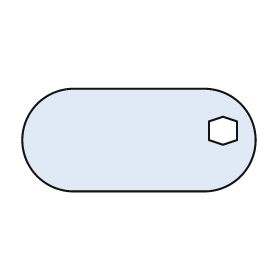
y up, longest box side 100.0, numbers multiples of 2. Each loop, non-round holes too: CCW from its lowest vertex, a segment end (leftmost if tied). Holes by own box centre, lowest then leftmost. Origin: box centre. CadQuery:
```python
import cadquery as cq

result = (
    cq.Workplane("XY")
    .moveTo(-28.0, -22.0)
    .lineTo(28.0, -22.0)
    .threePointArc((50.0, 0.0), (28.0, 22.0))
    .lineTo(-28.0, 22.0)
    .threePointArc((-50.0, 0.0), (-28.0, -22.0))
    .close()
    .moveTo(36.0, -2.0)
    .lineTo(42.0, 0.0)
    .lineTo(42.0, 8.0)
    .lineTo(36.0, 10.0)
    .lineTo(30.0, 8.0)
    .lineTo(30.0, 0.0)
    .close()
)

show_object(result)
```